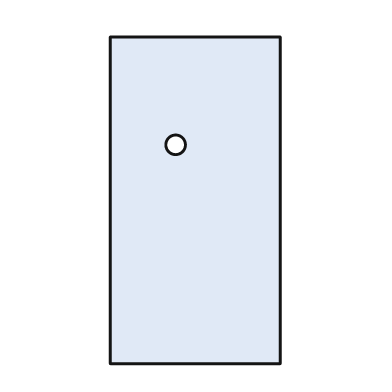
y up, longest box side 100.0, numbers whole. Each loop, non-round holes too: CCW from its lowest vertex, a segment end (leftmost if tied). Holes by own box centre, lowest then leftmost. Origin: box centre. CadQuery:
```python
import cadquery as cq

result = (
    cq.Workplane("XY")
    .moveTo(-26.0, -50.0)
    .lineTo(26.0, -50.0)
    .lineTo(26.0, 50.0)
    .lineTo(-26.0, 50.0)
    .close()
    .moveTo(-6.0, 17.0)
    .circle(3.0)
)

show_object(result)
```